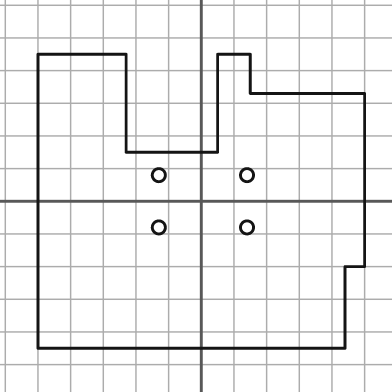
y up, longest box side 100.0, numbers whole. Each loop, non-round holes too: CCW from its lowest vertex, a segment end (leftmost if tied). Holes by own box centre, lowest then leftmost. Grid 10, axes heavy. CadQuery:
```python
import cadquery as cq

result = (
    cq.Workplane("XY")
    .moveTo(-50.0, -45.0)
    .lineTo(44.0, -45.0)
    .lineTo(44.0, -20.0)
    .lineTo(50.0, -20.0)
    .lineTo(50.0, 33.0)
    .lineTo(15.0, 33.0)
    .lineTo(15.0, 45.0)
    .lineTo(5.0, 45.0)
    .lineTo(5.0, 15.0)
    .lineTo(-23.0, 15.0)
    .lineTo(-23.0, 45.0)
    .lineTo(-50.0, 45.0)
    .close()
    .moveTo(-13.0, -8.0)
    .circle(2.0)
    .moveTo(14.0, -8.0)
    .circle(2.0)
    .moveTo(-13.0, 8.0)
    .circle(2.0)
    .moveTo(14.0, 8.0)
    .circle(2.0)
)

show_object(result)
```